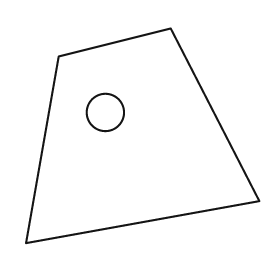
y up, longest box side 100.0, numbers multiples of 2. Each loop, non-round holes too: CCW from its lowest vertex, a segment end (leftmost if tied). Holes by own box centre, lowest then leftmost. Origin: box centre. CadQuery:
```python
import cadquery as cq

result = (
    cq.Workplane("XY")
    .moveTo(-50.0, -46.0)
    .lineTo(50.0, -28.0)
    .lineTo(12.0, 46.0)
    .lineTo(-36.0, 34.0)
    .close()
    .moveTo(-16.0, 10.0)
    .circle(8.0)
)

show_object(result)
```